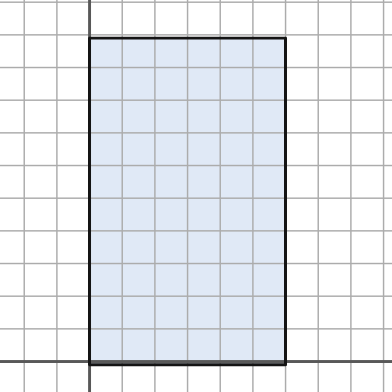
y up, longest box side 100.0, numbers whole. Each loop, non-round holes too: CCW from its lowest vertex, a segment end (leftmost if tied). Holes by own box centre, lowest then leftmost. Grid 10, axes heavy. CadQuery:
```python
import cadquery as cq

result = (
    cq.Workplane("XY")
    .moveTo(0.0, -1.0)
    .lineTo(60.0, -1.0)
    .lineTo(60.0, 99.0)
    .lineTo(0.0, 99.0)
    .close()
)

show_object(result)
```